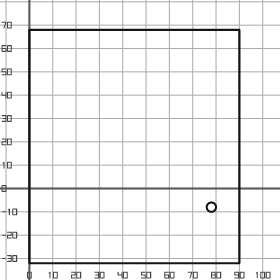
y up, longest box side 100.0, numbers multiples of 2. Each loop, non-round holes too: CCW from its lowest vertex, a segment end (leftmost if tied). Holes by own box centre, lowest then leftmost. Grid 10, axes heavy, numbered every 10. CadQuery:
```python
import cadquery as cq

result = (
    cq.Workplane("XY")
    .moveTo(0.0, -32.0)
    .lineTo(90.0, -32.0)
    .lineTo(90.0, 68.0)
    .lineTo(0.0, 68.0)
    .close()
    .moveTo(78.0, -8.0)
    .circle(2.0)
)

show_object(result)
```